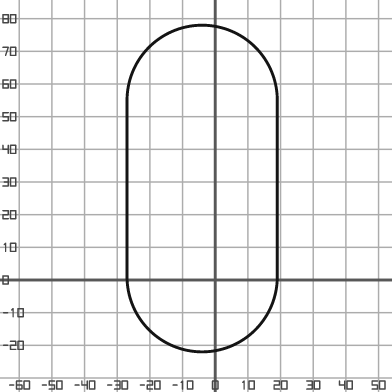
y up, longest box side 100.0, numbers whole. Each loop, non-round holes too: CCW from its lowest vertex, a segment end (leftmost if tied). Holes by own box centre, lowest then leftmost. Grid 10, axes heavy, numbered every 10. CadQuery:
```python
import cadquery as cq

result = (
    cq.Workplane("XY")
    .moveTo(-27.0, 1.0)
    .threePointArc((-4.0, -22.0), (19.0, 1.0))
    .lineTo(19.0, 55.0)
    .threePointArc((-4.0, 78.0), (-27.0, 55.0))
    .close()
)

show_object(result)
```